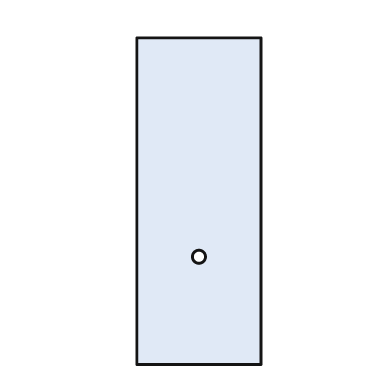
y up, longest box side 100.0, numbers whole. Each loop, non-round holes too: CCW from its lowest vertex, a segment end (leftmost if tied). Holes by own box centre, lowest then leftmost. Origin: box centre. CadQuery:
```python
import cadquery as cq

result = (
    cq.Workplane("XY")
    .moveTo(-19.0, -50.0)
    .lineTo(19.0, -50.0)
    .lineTo(19.0, 50.0)
    .lineTo(-19.0, 50.0)
    .close()
    .moveTo(0.0, -17.0)
    .circle(2.0)
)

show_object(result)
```